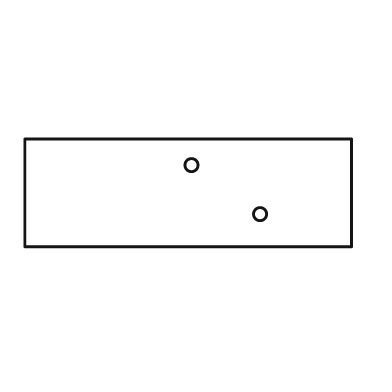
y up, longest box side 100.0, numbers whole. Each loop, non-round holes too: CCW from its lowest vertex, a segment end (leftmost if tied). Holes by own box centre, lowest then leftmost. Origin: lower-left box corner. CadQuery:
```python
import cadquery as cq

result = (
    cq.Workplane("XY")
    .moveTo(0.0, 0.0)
    .lineTo(100.0, 0.0)
    .lineTo(100.0, 33.0)
    .lineTo(0.0, 33.0)
    .close()
    .moveTo(72.0, 10.0)
    .circle(2.0)
    .moveTo(51.0, 25.0)
    .circle(2.0)
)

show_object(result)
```